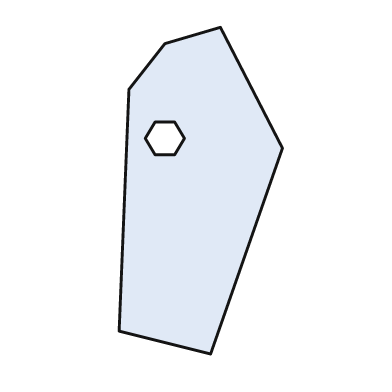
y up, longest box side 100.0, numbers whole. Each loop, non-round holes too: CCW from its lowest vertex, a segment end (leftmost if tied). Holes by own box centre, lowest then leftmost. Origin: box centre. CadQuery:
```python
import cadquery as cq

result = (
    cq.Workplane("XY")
    .moveTo(3.0, -50.0)
    .lineTo(25.0, 13.0)
    .lineTo(6.0, 50.0)
    .lineTo(-11.0, 45.0)
    .lineTo(-22.0, 31.0)
    .lineTo(-25.0, -43.0)
    .close()
    .moveTo(-14.0, 11.0)
    .lineTo(-8.0, 11.0)
    .lineTo(-5.0, 16.0)
    .lineTo(-8.0, 21.0)
    .lineTo(-14.0, 21.0)
    .lineTo(-17.0, 16.0)
    .close()
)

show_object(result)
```